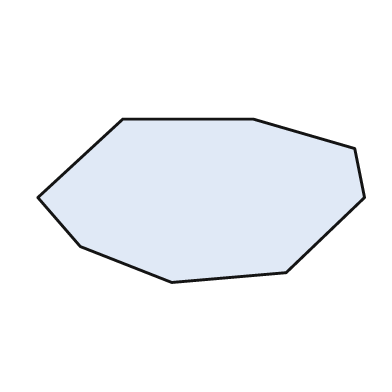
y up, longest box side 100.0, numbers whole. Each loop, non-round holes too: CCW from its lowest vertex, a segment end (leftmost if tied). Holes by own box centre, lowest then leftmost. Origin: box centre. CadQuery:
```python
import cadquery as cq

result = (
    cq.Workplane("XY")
    .moveTo(-9.0, -25.0)
    .lineTo(26.0, -22.0)
    .lineTo(50.0, 1.0)
    .lineTo(47.0, 16.0)
    .lineTo(16.0, 25.0)
    .lineTo(-24.0, 25.0)
    .lineTo(-50.0, 1.0)
    .lineTo(-37.0, -14.0)
    .close()
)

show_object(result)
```